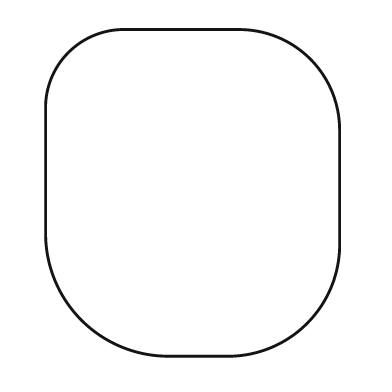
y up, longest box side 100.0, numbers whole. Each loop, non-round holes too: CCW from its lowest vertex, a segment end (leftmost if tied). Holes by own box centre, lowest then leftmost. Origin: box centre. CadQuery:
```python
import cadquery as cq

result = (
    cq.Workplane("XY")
    .moveTo(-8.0, -50.0)
    .lineTo(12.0, -50.0)
    .threePointArc((35.0, -40.0), (45.0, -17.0))
    .lineTo(45.0, 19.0)
    .threePointArc((36.0, 41.0), (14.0, 50.0))
    .lineTo(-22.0, 50.0)
    .threePointArc((-38.0, 43.0), (-45.0, 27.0))
    .lineTo(-45.0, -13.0)
    .threePointArc((-34.0, -39.0), (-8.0, -50.0))
    .close()
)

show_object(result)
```